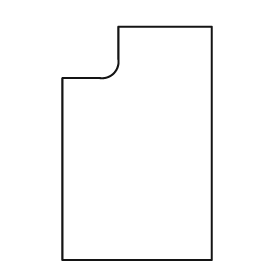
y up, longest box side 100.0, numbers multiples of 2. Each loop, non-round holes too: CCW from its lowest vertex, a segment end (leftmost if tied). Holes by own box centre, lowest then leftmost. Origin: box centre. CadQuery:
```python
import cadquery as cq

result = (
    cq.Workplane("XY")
    .moveTo(-32.0, -50.0)
    .lineTo(32.0, -50.0)
    .lineTo(32.0, 50.0)
    .lineTo(-8.0, 50.0)
    .lineTo(-8.0, 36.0)
    .threePointArc((-10.0, 30.0), (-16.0, 28.0))
    .lineTo(-32.0, 28.0)
    .close()
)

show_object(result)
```